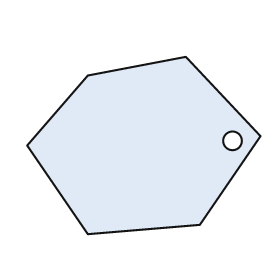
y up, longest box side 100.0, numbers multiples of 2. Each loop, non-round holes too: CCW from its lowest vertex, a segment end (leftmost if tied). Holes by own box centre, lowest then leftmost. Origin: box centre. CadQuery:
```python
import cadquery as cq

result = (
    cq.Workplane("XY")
    .moveTo(-24.0, -38.0)
    .lineTo(24.0, -34.0)
    .lineTo(50.0, 4.0)
    .lineTo(18.0, 38.0)
    .lineTo(-24.0, 30.0)
    .lineTo(-50.0, 0.0)
    .close()
    .moveTo(38.0, 2.0)
    .circle(4.0)
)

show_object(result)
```